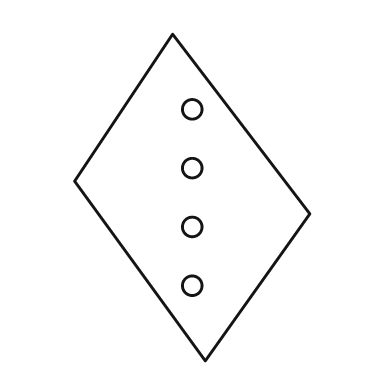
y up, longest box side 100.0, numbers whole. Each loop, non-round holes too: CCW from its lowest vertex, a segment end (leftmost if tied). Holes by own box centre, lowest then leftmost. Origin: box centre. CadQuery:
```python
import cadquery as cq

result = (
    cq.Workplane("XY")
    .moveTo(4.0, -50.0)
    .lineTo(36.0, -5.0)
    .lineTo(-6.0, 50.0)
    .lineTo(-36.0, 5.0)
    .close()
    .moveTo(0.0, -27.0)
    .circle(3.0)
    .moveTo(0.0, -9.0)
    .circle(3.0)
    .moveTo(0.0, 9.0)
    .circle(3.0)
    .moveTo(0.0, 27.0)
    .circle(3.0)
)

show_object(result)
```